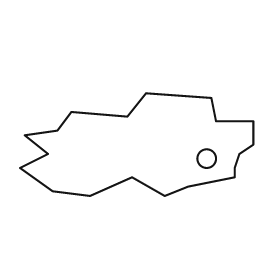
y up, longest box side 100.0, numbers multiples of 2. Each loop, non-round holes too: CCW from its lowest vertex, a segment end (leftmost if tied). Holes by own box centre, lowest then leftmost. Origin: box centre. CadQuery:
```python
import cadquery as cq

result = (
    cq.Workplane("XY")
    .moveTo(-20.0, -22.0)
    .lineTo(-2.0, -14.0)
    .lineTo(12.0, -22.0)
    .lineTo(22.0, -18.0)
    .lineTo(42.0, -14.0)
    .lineTo(42.0, -10.0)
    .lineTo(44.0, -4.0)
    .lineTo(50.0, 0.0)
    .lineTo(50.0, 10.0)
    .lineTo(34.0, 10.0)
    .lineTo(32.0, 20.0)
    .lineTo(4.0, 22.0)
    .lineTo(-4.0, 12.0)
    .lineTo(-28.0, 14.0)
    .lineTo(-34.0, 6.0)
    .lineTo(-48.0, 4.0)
    .lineTo(-38.0, -4.0)
    .lineTo(-50.0, -10.0)
    .lineTo(-36.0, -20.0)
    .close()
    .moveTo(30.0, -6.0)
    .circle(4.0)
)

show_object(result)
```